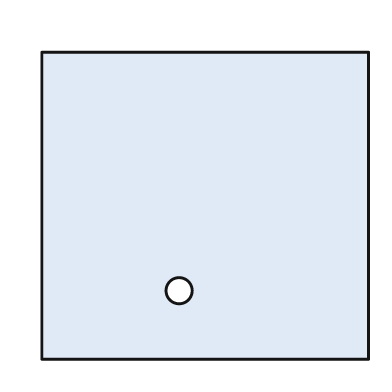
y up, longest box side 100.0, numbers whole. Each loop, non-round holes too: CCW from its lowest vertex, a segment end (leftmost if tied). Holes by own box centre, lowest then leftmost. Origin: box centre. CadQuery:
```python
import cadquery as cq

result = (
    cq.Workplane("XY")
    .moveTo(-50.0, -47.0)
    .lineTo(50.0, -47.0)
    .lineTo(50.0, 47.0)
    .lineTo(-50.0, 47.0)
    .close()
    .moveTo(-8.0, -26.0)
    .circle(4.0)
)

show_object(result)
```